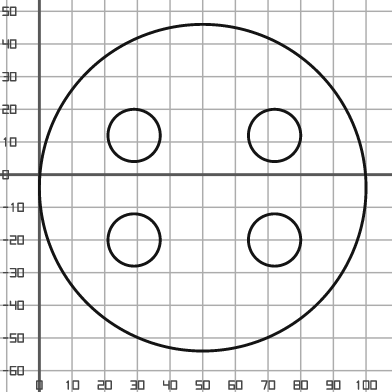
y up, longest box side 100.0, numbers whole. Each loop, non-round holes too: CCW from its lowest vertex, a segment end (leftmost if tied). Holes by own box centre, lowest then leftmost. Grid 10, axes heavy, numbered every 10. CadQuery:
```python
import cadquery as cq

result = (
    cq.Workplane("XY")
    .moveTo(50.0, -4.0)
    .circle(50.0)
    .moveTo(29.0, -20.0)
    .circle(8.0)
    .moveTo(72.0, -20.0)
    .circle(8.0)
    .moveTo(29.0, 12.0)
    .circle(8.0)
    .moveTo(72.0, 12.0)
    .circle(8.0)
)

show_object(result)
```